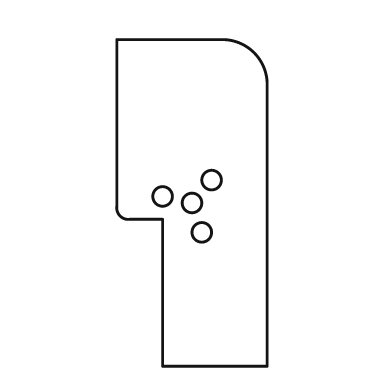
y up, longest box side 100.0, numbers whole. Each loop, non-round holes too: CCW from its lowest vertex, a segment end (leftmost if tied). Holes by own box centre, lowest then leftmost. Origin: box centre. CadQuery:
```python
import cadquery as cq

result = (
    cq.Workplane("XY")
    .moveTo(-9.0, -50.0)
    .lineTo(23.0, -50.0)
    .lineTo(23.0, 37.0)
    .threePointArc((19.0, 46.0), (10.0, 50.0))
    .lineTo(-23.0, 50.0)
    .lineTo(-23.0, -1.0)
    .threePointArc((-22.0, -4.0), (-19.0, -5.0))
    .lineTo(-9.0, -5.0)
    .close()
    .moveTo(3.0, -9.0)
    .circle(3.0)
    .moveTo(0.0, 0.0)
    .circle(3.0)
    .moveTo(-9.0, 2.0)
    .circle(3.0)
    .moveTo(6.0, 7.0)
    .circle(3.0)
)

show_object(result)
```